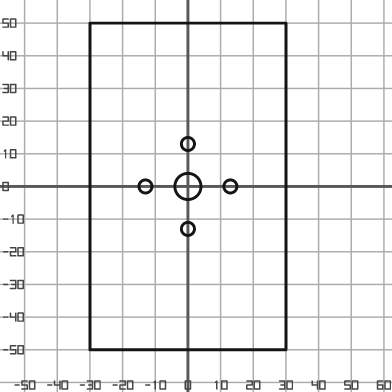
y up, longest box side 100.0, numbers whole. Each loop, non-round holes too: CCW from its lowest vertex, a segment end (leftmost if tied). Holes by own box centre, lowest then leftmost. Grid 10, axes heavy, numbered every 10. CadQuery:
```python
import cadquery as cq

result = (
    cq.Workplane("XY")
    .moveTo(-30.0, -50.0)
    .lineTo(30.0, -50.0)
    .lineTo(30.0, 50.0)
    .lineTo(-30.0, 50.0)
    .close()
    .moveTo(0.0, -13.0)
    .circle(2.0)
    .moveTo(-13.0, 0.0)
    .circle(2.0)
    .moveTo(0.0, 0.0)
    .circle(4.0)
    .moveTo(13.0, 0.0)
    .circle(2.0)
    .moveTo(0.0, 13.0)
    .circle(2.0)
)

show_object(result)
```